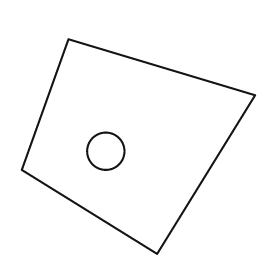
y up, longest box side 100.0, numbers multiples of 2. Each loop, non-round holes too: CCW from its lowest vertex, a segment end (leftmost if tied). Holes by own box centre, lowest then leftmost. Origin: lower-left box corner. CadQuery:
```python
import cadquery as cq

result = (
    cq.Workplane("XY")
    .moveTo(58.0, 0.0)
    .lineTo(100.0, 68.0)
    .lineTo(20.0, 92.0)
    .lineTo(0.0, 36.0)
    .close()
    .moveTo(36.0, 44.0)
    .circle(8.0)
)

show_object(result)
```